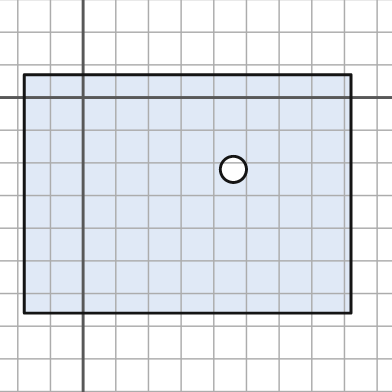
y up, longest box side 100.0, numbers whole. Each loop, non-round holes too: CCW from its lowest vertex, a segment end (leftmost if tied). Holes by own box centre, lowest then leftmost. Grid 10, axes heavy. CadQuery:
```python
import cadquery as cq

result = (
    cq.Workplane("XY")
    .moveTo(-18.0, -66.0)
    .lineTo(82.0, -66.0)
    .lineTo(82.0, 7.0)
    .lineTo(-18.0, 7.0)
    .close()
    .moveTo(46.0, -22.0)
    .circle(4.0)
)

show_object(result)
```